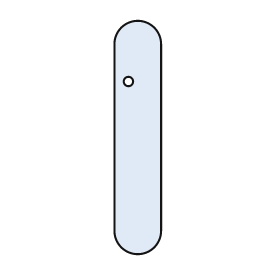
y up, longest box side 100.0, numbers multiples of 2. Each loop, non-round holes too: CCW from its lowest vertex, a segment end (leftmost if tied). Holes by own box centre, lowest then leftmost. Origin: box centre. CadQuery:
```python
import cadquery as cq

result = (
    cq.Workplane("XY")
    .moveTo(-10.0, -40.0)
    .threePointArc((0.0, -50.0), (10.0, -40.0))
    .lineTo(10.0, 40.0)
    .threePointArc((0.0, 50.0), (-10.0, 40.0))
    .close()
    .moveTo(-4.0, 24.0)
    .circle(2.0)
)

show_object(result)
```